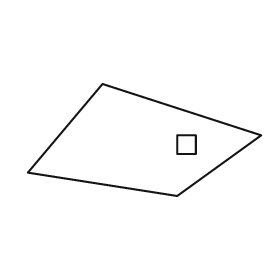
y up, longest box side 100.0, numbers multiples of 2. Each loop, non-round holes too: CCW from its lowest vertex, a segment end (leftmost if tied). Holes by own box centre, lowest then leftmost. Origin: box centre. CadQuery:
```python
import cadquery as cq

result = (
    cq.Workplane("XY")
    .moveTo(14.0, -24.0)
    .lineTo(50.0, 2.0)
    .lineTo(-18.0, 24.0)
    .lineTo(-50.0, -14.0)
    .close()
    .moveTo(14.0, -6.0)
    .lineTo(22.0, -6.0)
    .lineTo(22.0, 2.0)
    .lineTo(14.0, 2.0)
    .close()
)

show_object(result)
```